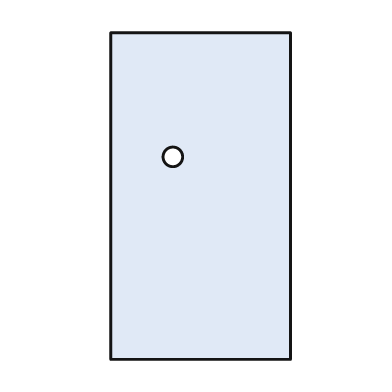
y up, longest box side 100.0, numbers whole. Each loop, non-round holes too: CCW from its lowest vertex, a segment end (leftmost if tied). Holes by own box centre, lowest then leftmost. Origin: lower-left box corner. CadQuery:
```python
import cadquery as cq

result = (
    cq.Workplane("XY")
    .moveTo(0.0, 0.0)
    .lineTo(55.0, 0.0)
    .lineTo(55.0, 100.0)
    .lineTo(0.0, 100.0)
    .close()
    .moveTo(19.0, 62.0)
    .circle(3.0)
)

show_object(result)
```